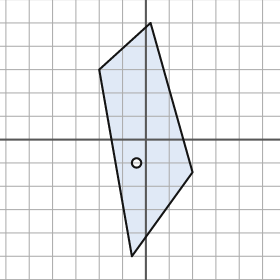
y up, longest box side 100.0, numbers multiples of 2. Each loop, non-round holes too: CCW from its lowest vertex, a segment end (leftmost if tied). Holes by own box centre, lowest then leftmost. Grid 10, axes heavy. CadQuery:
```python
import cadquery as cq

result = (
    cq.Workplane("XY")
    .moveTo(-6.0, -50.0)
    .lineTo(20.0, -14.0)
    .lineTo(2.0, 50.0)
    .lineTo(-20.0, 30.0)
    .close()
    .moveTo(-4.0, -10.0)
    .circle(2.0)
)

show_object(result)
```